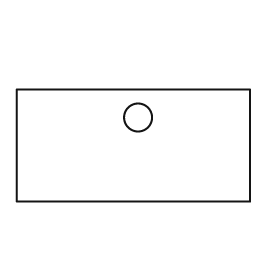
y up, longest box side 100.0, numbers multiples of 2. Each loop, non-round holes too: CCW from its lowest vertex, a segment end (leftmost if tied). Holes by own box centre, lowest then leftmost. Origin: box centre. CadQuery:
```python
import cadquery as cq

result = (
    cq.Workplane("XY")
    .moveTo(-50.0, -24.0)
    .lineTo(50.0, -24.0)
    .lineTo(50.0, 24.0)
    .lineTo(-50.0, 24.0)
    .close()
    .moveTo(2.0, 12.0)
    .circle(6.0)
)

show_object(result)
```